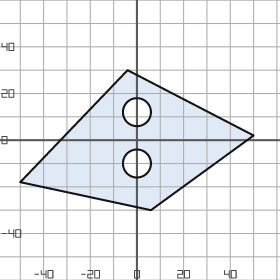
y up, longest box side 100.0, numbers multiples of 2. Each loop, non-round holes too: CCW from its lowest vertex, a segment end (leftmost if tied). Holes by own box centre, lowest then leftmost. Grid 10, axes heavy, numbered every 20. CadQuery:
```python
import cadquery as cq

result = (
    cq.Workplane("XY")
    .moveTo(6.0, -30.0)
    .lineTo(50.0, 2.0)
    .lineTo(-4.0, 30.0)
    .lineTo(-50.0, -18.0)
    .close()
    .moveTo(0.0, -10.0)
    .circle(6.0)
    .moveTo(0.0, 12.0)
    .circle(6.0)
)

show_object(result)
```